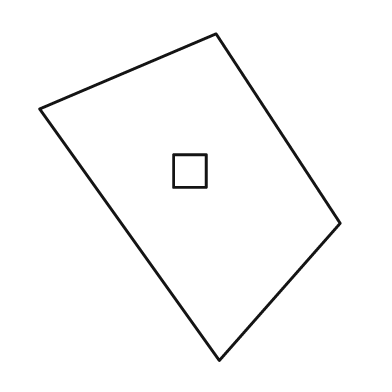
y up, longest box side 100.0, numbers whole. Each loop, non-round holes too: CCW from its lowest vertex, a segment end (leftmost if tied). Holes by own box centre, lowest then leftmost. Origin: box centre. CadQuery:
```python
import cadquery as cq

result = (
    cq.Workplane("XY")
    .moveTo(9.0, -50.0)
    .lineTo(46.0, -8.0)
    .lineTo(8.0, 50.0)
    .lineTo(-46.0, 27.0)
    .close()
    .moveTo(-5.0, 3.0)
    .lineTo(5.0, 3.0)
    .lineTo(5.0, 13.0)
    .lineTo(-5.0, 13.0)
    .close()
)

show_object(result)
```